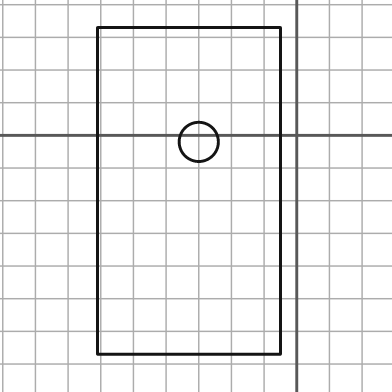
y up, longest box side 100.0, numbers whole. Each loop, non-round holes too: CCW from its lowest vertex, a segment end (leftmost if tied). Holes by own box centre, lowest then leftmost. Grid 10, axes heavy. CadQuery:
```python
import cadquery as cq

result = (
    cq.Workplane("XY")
    .moveTo(-61.0, -67.0)
    .lineTo(-5.0, -67.0)
    .lineTo(-5.0, 33.0)
    .lineTo(-61.0, 33.0)
    .close()
    .moveTo(-30.0, -2.0)
    .circle(6.0)
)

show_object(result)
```